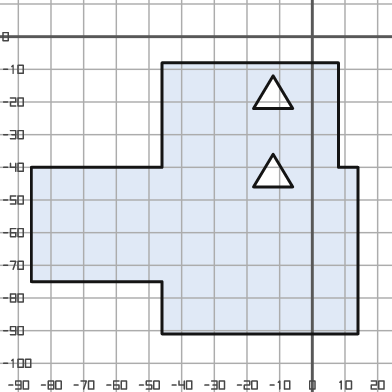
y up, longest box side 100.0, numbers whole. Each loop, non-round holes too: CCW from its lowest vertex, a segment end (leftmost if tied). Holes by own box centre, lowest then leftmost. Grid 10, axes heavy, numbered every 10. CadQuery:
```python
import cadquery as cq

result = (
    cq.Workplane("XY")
    .moveTo(-46.0, -91.0)
    .lineTo(14.0, -91.0)
    .lineTo(14.0, -40.0)
    .lineTo(8.0, -40.0)
    .lineTo(8.0, -8.0)
    .lineTo(-46.0, -8.0)
    .lineTo(-46.0, -40.0)
    .lineTo(-86.0, -40.0)
    .lineTo(-86.0, -75.0)
    .lineTo(-46.0, -75.0)
    .close()
    .moveTo(-18.0, -46.0)
    .lineTo(-6.0, -46.0)
    .lineTo(-12.0, -36.0)
    .close()
    .moveTo(-18.0, -22.0)
    .lineTo(-6.0, -22.0)
    .lineTo(-12.0, -12.0)
    .close()
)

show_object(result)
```